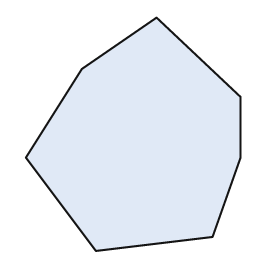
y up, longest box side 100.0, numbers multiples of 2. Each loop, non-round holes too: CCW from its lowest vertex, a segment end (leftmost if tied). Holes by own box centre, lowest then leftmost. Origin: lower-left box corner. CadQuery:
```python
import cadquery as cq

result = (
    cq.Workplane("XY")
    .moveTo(30.0, 0.0)
    .lineTo(80.0, 6.0)
    .lineTo(92.0, 40.0)
    .lineTo(92.0, 66.0)
    .lineTo(56.0, 100.0)
    .lineTo(24.0, 78.0)
    .lineTo(0.0, 40.0)
    .close()
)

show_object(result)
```